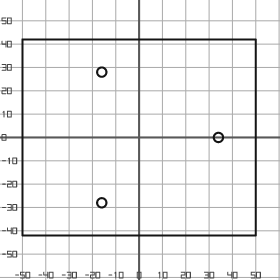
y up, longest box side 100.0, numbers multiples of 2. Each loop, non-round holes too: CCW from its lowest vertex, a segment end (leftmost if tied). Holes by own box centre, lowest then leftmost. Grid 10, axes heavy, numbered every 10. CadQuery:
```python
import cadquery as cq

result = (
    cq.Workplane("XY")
    .moveTo(-50.0, -42.0)
    .lineTo(50.0, -42.0)
    .lineTo(50.0, 42.0)
    .lineTo(-50.0, 42.0)
    .close()
    .moveTo(-16.0, -28.0)
    .circle(2.0)
    .moveTo(34.0, 0.0)
    .circle(2.0)
    .moveTo(-16.0, 28.0)
    .circle(2.0)
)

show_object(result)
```